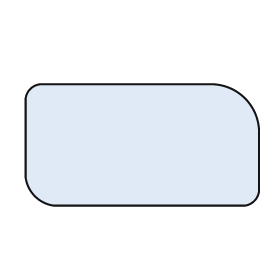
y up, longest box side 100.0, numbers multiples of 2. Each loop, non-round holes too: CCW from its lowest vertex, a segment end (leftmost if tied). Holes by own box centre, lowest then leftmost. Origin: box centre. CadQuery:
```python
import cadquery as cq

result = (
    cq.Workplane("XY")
    .moveTo(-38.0, -26.0)
    .lineTo(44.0, -26.0)
    .threePointArc((48.0, -24.0), (50.0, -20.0))
    .lineTo(50.0, 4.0)
    .threePointArc((44.0, 20.0), (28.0, 26.0))
    .lineTo(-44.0, 26.0)
    .threePointArc((-48.0, 24.0), (-50.0, 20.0))
    .lineTo(-50.0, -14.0)
    .threePointArc((-46.0, -22.0), (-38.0, -26.0))
    .close()
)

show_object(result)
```